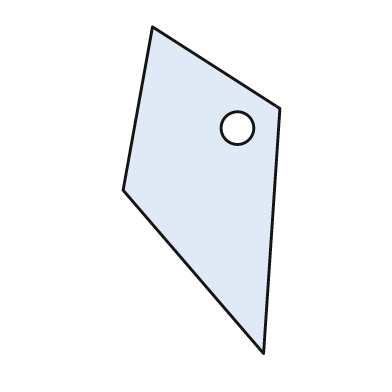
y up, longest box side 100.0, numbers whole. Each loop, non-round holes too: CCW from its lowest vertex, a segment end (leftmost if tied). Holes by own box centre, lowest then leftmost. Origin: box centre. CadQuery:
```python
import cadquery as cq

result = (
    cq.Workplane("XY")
    .moveTo(19.0, -50.0)
    .lineTo(24.0, 25.0)
    .lineTo(-15.0, 50.0)
    .lineTo(-24.0, 0.0)
    .close()
    .moveTo(11.0, 19.0)
    .circle(5.0)
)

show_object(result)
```